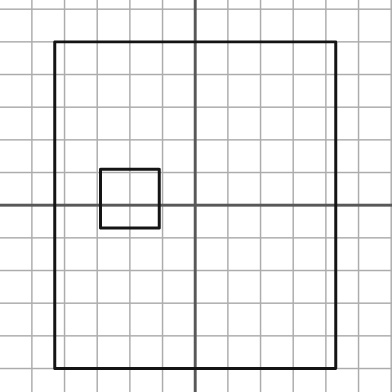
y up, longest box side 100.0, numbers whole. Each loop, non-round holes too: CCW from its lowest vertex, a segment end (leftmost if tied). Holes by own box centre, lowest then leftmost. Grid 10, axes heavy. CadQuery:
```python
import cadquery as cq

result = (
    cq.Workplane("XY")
    .moveTo(-43.0, -50.0)
    .lineTo(43.0, -50.0)
    .lineTo(43.0, 50.0)
    .lineTo(-43.0, 50.0)
    .close()
    .moveTo(-29.0, -7.0)
    .lineTo(-11.0, -7.0)
    .lineTo(-11.0, 11.0)
    .lineTo(-29.0, 11.0)
    .close()
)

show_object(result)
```